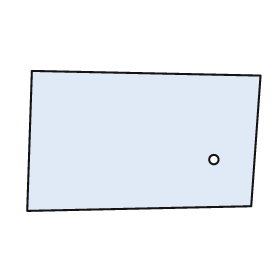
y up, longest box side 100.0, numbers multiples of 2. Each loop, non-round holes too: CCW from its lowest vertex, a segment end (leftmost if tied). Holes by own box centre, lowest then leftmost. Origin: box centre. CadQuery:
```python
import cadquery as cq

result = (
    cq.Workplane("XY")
    .moveTo(-50.0, -30.0)
    .lineTo(46.0, -28.0)
    .lineTo(50.0, 28.0)
    .lineTo(-48.0, 30.0)
    .close()
    .moveTo(30.0, -8.0)
    .circle(2.0)
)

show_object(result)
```